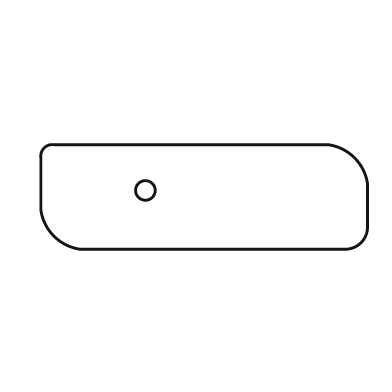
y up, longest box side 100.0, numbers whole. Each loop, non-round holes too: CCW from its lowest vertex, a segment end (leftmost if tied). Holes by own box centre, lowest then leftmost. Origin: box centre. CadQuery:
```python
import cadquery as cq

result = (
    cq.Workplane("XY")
    .moveTo(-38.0, -16.0)
    .lineTo(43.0, -16.0)
    .threePointArc((48.0, -14.0), (50.0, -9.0))
    .lineTo(50.0, 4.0)
    .threePointArc((46.0, 12.0), (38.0, 16.0))
    .lineTo(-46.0, 16.0)
    .threePointArc((-49.0, 15.0), (-50.0, 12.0))
    .lineTo(-50.0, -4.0)
    .threePointArc((-46.0, -12.0), (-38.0, -16.0))
    .close()
    .moveTo(-18.0, 2.0)
    .circle(3.0)
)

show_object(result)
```